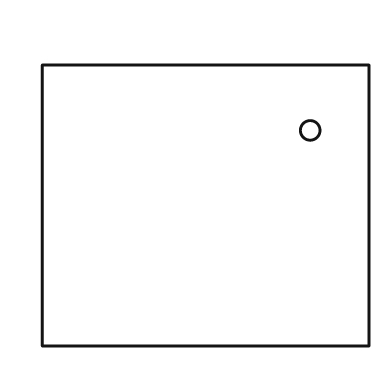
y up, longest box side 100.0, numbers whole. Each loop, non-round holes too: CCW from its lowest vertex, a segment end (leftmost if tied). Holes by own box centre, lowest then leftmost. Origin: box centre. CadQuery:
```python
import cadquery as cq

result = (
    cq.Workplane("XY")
    .moveTo(-50.0, -43.0)
    .lineTo(50.0, -43.0)
    .lineTo(50.0, 43.0)
    .lineTo(-50.0, 43.0)
    .close()
    .moveTo(32.0, 23.0)
    .circle(3.0)
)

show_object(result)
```